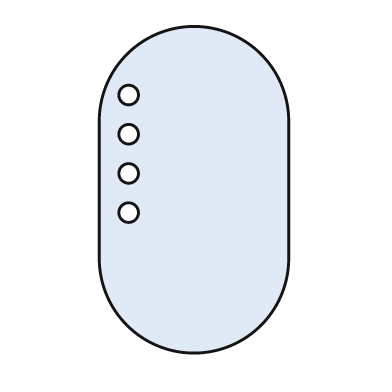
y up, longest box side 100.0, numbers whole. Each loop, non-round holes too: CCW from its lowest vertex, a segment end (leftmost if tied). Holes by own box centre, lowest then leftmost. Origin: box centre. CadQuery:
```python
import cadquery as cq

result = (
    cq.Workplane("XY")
    .moveTo(-29.0, -21.0)
    .threePointArc((0.0, -50.0), (29.0, -21.0))
    .lineTo(29.0, 21.0)
    .threePointArc((0.0, 50.0), (-29.0, 21.0))
    .close()
    .moveTo(-20.0, -7.0)
    .circle(3.0)
    .moveTo(-20.0, 5.0)
    .circle(3.0)
    .moveTo(-20.0, 17.0)
    .circle(3.0)
    .moveTo(-20.0, 29.0)
    .circle(3.0)
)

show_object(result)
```